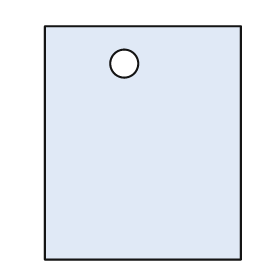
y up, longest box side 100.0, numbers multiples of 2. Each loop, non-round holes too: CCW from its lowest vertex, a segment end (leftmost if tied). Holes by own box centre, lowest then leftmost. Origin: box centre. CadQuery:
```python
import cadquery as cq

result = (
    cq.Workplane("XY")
    .moveTo(-42.0, -50.0)
    .lineTo(42.0, -50.0)
    .lineTo(42.0, 50.0)
    .lineTo(-42.0, 50.0)
    .close()
    .moveTo(-8.0, 34.0)
    .circle(6.0)
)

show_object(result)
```